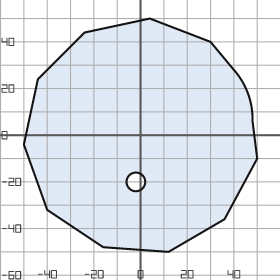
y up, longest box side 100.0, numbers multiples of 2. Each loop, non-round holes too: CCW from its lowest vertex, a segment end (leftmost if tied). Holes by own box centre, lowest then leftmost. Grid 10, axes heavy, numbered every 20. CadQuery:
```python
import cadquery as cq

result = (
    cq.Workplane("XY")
    .moveTo(12.0, -50.0)
    .lineTo(36.0, -36.0)
    .lineTo(50.0, -10.0)
    .lineTo(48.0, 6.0)
    .threePointArc((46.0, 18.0), (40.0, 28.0))
    .lineTo(30.0, 40.0)
    .lineTo(4.0, 50.0)
    .lineTo(-24.0, 44.0)
    .lineTo(-44.0, 24.0)
    .lineTo(-50.0, -4.0)
    .lineTo(-40.0, -32.0)
    .lineTo(-16.0, -48.0)
    .close()
    .moveTo(-2.0, -20.0)
    .circle(4.0)
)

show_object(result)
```